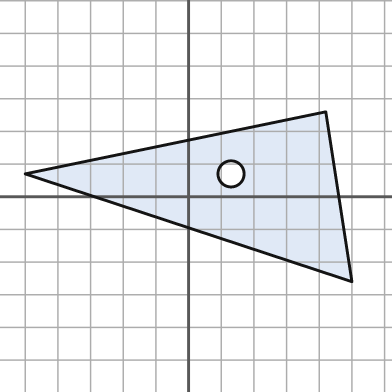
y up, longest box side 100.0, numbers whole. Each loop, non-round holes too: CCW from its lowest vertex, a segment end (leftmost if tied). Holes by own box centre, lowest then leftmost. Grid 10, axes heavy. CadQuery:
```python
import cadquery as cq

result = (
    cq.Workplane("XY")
    .moveTo(50.0, -26.0)
    .lineTo(42.0, 26.0)
    .lineTo(-50.0, 7.0)
    .close()
    .moveTo(13.0, 7.0)
    .circle(4.0)
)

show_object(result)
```